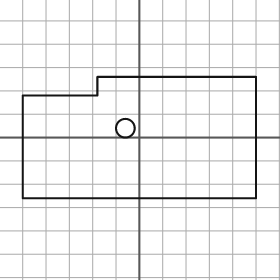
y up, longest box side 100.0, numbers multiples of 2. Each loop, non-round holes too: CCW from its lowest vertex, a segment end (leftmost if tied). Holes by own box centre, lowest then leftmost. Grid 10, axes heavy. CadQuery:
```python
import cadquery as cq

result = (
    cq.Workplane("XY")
    .moveTo(-50.0, -26.0)
    .lineTo(50.0, -26.0)
    .lineTo(50.0, 26.0)
    .lineTo(-18.0, 26.0)
    .lineTo(-18.0, 18.0)
    .lineTo(-50.0, 18.0)
    .close()
    .moveTo(-6.0, 4.0)
    .circle(4.0)
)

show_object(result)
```